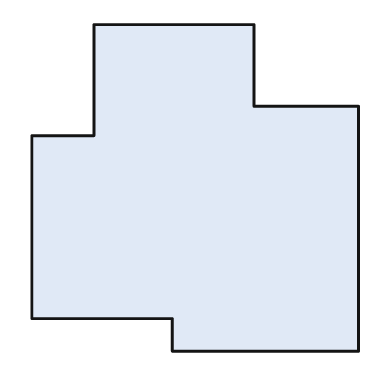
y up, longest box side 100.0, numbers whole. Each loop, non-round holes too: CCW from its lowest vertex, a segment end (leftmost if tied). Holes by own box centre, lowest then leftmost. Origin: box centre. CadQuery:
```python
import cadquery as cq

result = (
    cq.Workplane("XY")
    .moveTo(-7.0, -50.0)
    .lineTo(50.0, -50.0)
    .lineTo(50.0, 25.0)
    .lineTo(18.0, 25.0)
    .lineTo(18.0, 50.0)
    .lineTo(-31.0, 50.0)
    .lineTo(-31.0, 16.0)
    .lineTo(-50.0, 16.0)
    .lineTo(-50.0, -40.0)
    .lineTo(-7.0, -40.0)
    .close()
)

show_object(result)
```